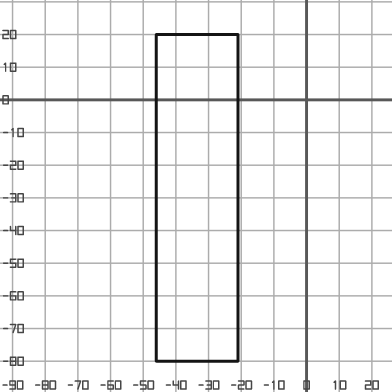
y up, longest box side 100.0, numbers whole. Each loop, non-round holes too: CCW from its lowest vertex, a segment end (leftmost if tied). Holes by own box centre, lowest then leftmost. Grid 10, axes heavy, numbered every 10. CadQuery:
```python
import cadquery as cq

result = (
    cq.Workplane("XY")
    .moveTo(-46.0, -80.0)
    .lineTo(-21.0, -80.0)
    .lineTo(-21.0, 20.0)
    .lineTo(-46.0, 20.0)
    .close()
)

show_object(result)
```